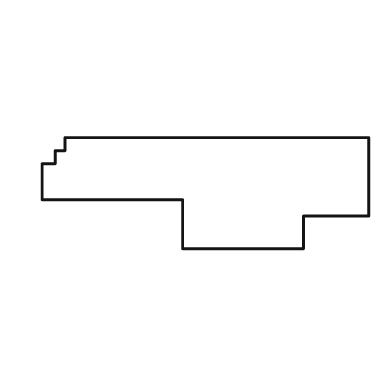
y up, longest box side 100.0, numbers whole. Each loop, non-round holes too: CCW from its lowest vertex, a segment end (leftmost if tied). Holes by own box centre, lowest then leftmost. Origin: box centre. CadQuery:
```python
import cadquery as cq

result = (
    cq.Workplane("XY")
    .moveTo(-7.0, -17.0)
    .lineTo(30.0, -17.0)
    .lineTo(30.0, -7.0)
    .lineTo(50.0, -7.0)
    .lineTo(50.0, 17.0)
    .lineTo(-43.0, 17.0)
    .lineTo(-43.0, 13.0)
    .lineTo(-46.0, 13.0)
    .lineTo(-46.0, 9.0)
    .lineTo(-50.0, 9.0)
    .lineTo(-50.0, -2.0)
    .lineTo(-7.0, -2.0)
    .close()
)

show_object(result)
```